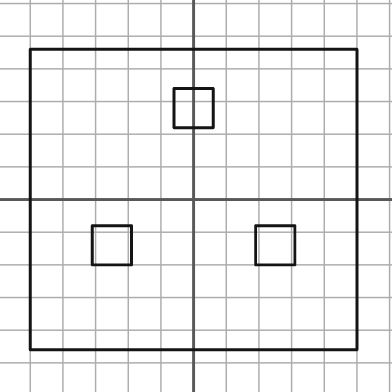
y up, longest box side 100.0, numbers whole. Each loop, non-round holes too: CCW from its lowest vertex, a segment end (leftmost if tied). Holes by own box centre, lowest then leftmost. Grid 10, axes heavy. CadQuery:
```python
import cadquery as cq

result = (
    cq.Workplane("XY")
    .moveTo(-50.0, -46.0)
    .lineTo(50.0, -46.0)
    .lineTo(50.0, 46.0)
    .lineTo(-50.0, 46.0)
    .close()
    .moveTo(-31.0, -20.0)
    .lineTo(-19.0, -20.0)
    .lineTo(-19.0, -8.0)
    .lineTo(-31.0, -8.0)
    .close()
    .moveTo(19.0, -20.0)
    .lineTo(31.0, -20.0)
    .lineTo(31.0, -8.0)
    .lineTo(19.0, -8.0)
    .close()
    .moveTo(-6.0, 22.0)
    .lineTo(6.0, 22.0)
    .lineTo(6.0, 34.0)
    .lineTo(-6.0, 34.0)
    .close()
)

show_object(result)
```